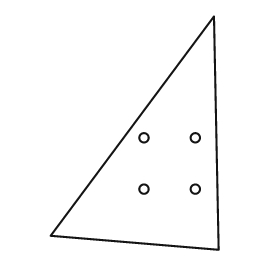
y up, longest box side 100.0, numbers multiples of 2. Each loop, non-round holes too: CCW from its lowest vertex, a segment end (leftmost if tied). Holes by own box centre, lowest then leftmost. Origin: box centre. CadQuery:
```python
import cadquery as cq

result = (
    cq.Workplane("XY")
    .moveTo(36.0, -50.0)
    .lineTo(34.0, 50.0)
    .lineTo(-36.0, -44.0)
    .close()
    .moveTo(4.0, -24.0)
    .circle(2.0)
    .moveTo(26.0, -24.0)
    .circle(2.0)
    .moveTo(4.0, -2.0)
    .circle(2.0)
    .moveTo(26.0, -2.0)
    .circle(2.0)
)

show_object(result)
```